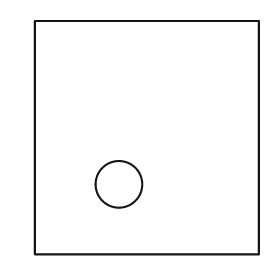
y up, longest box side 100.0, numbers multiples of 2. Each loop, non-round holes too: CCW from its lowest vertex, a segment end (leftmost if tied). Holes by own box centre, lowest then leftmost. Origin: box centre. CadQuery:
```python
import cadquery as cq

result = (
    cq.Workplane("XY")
    .moveTo(-48.0, -50.0)
    .lineTo(48.0, -50.0)
    .lineTo(48.0, 50.0)
    .lineTo(-48.0, 50.0)
    .close()
    .moveTo(-12.0, -20.0)
    .circle(10.0)
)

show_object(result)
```